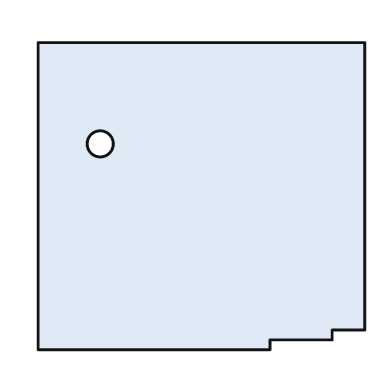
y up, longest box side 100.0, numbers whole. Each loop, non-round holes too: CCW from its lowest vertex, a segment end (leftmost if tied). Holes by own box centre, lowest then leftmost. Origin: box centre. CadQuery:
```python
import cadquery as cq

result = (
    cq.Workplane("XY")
    .moveTo(-50.0, -47.0)
    .lineTo(21.0, -47.0)
    .lineTo(21.0, -44.0)
    .lineTo(40.0, -44.0)
    .lineTo(40.0, -41.0)
    .lineTo(50.0, -41.0)
    .lineTo(50.0, 47.0)
    .lineTo(-50.0, 47.0)
    .close()
    .moveTo(-31.0, 16.0)
    .circle(4.0)
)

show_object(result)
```